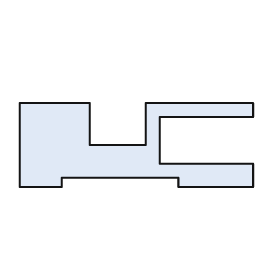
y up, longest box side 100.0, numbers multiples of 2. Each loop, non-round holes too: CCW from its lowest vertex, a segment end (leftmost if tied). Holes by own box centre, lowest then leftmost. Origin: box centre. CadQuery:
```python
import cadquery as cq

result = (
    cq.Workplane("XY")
    .moveTo(-50.0, -18.0)
    .lineTo(-32.0, -18.0)
    .lineTo(-32.0, -14.0)
    .lineTo(18.0, -14.0)
    .lineTo(18.0, -18.0)
    .lineTo(50.0, -18.0)
    .lineTo(50.0, -8.0)
    .lineTo(10.0, -8.0)
    .lineTo(10.0, 12.0)
    .lineTo(50.0, 12.0)
    .lineTo(50.0, 18.0)
    .lineTo(4.0, 18.0)
    .lineTo(4.0, 0.0)
    .lineTo(-20.0, 0.0)
    .lineTo(-20.0, 18.0)
    .lineTo(-50.0, 18.0)
    .close()
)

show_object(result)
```